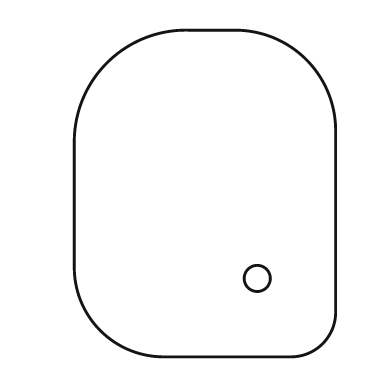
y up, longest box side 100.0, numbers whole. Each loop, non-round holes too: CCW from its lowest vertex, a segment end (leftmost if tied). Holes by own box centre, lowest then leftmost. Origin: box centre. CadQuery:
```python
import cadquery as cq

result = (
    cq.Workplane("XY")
    .moveTo(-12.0, -50.0)
    .lineTo(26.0, -50.0)
    .threePointArc((36.0, -46.0), (40.0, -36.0))
    .lineTo(40.0, 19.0)
    .threePointArc((31.0, 41.0), (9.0, 50.0))
    .lineTo(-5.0, 50.0)
    .threePointArc((-30.0, 40.0), (-40.0, 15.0))
    .lineTo(-40.0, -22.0)
    .threePointArc((-32.0, -42.0), (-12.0, -50.0))
    .close()
    .moveTo(16.0, -26.0)
    .circle(4.0)
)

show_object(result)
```